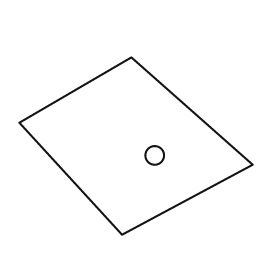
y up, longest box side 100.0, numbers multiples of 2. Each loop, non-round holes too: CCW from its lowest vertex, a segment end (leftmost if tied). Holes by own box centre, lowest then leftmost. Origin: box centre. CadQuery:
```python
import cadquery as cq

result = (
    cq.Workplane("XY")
    .moveTo(-6.0, -38.0)
    .lineTo(50.0, -8.0)
    .lineTo(-2.0, 38.0)
    .lineTo(-50.0, 10.0)
    .close()
    .moveTo(8.0, -4.0)
    .circle(4.0)
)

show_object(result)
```